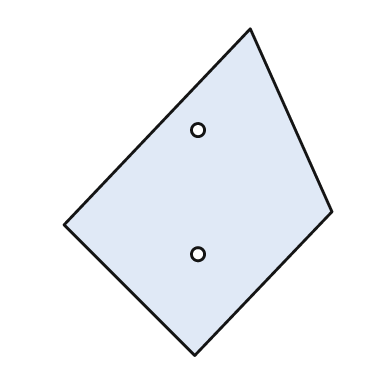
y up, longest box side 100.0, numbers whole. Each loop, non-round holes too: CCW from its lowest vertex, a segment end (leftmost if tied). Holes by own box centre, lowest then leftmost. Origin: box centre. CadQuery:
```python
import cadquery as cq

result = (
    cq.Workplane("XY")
    .moveTo(-1.0, -50.0)
    .lineTo(41.0, -6.0)
    .lineTo(16.0, 50.0)
    .lineTo(-41.0, -10.0)
    .close()
    .moveTo(0.0, -19.0)
    .circle(2.0)
    .moveTo(0.0, 19.0)
    .circle(2.0)
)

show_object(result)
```